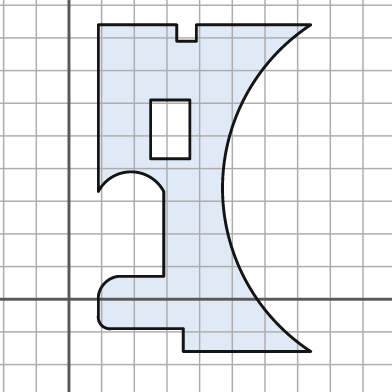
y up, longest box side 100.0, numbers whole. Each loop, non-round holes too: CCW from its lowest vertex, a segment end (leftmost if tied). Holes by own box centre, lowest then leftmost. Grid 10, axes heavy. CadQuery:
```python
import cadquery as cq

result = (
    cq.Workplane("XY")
    .moveTo(35.0, -16.0)
    .lineTo(74.0, -16.0)
    .threePointArc((47.0, 34.0), (74.0, 84.0))
    .lineTo(39.0, 84.0)
    .lineTo(39.0, 79.0)
    .lineTo(33.0, 79.0)
    .lineTo(33.0, 84.0)
    .lineTo(9.0, 84.0)
    .lineTo(9.0, 33.0)
    .threePointArc((19.0, 39.0), (29.0, 33.0))
    .lineTo(29.0, 7.0)
    .lineTo(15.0, 7.0)
    .threePointArc((11.0, 5.0), (9.0, 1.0))
    .lineTo(9.0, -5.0)
    .threePointArc((10.0, -8.0), (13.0, -9.0))
    .lineTo(35.0, -9.0)
    .close()
    .moveTo(25.0, 43.0)
    .lineTo(37.0, 43.0)
    .lineTo(37.0, 61.0)
    .lineTo(25.0, 61.0)
    .close()
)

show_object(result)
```